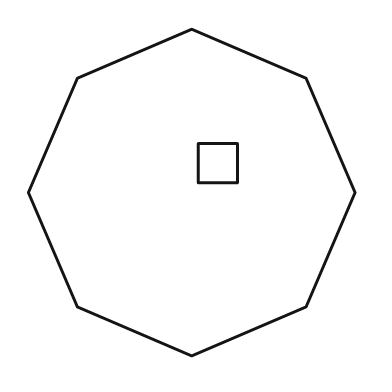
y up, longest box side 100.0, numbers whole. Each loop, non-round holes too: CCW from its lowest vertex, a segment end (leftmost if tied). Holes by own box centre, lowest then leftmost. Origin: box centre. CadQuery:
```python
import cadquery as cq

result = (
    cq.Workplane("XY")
    .moveTo(0.0, -50.0)
    .lineTo(35.0, -35.0)
    .lineTo(50.0, 0.0)
    .lineTo(35.0, 35.0)
    .lineTo(0.0, 50.0)
    .lineTo(-35.0, 35.0)
    .lineTo(-50.0, 0.0)
    .lineTo(-35.0, -35.0)
    .close()
    .moveTo(2.0, 3.0)
    .lineTo(14.0, 3.0)
    .lineTo(14.0, 15.0)
    .lineTo(2.0, 15.0)
    .close()
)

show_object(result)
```